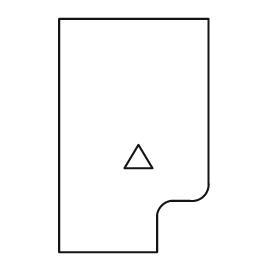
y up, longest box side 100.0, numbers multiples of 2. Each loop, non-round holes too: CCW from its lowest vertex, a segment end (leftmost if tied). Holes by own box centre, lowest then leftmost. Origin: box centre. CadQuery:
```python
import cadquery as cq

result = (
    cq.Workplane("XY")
    .moveTo(-32.0, -50.0)
    .lineTo(10.0, -50.0)
    .lineTo(10.0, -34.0)
    .threePointArc((12.0, -30.0), (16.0, -28.0))
    .lineTo(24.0, -28.0)
    .threePointArc((30.0, -26.0), (32.0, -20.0))
    .lineTo(32.0, 50.0)
    .lineTo(-32.0, 50.0)
    .close()
    .moveTo(-4.0, -14.0)
    .lineTo(8.0, -14.0)
    .lineTo(2.0, -4.0)
    .close()
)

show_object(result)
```